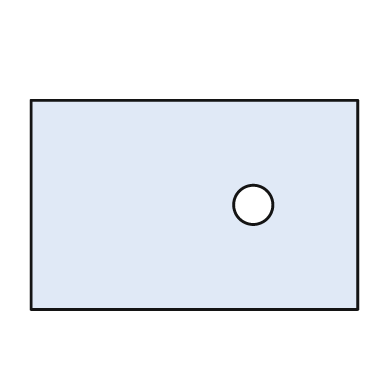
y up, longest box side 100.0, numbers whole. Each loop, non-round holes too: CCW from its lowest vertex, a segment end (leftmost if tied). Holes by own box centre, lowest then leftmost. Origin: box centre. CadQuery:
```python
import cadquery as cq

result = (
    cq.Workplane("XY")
    .moveTo(-50.0, -32.0)
    .lineTo(50.0, -32.0)
    .lineTo(50.0, 32.0)
    .lineTo(-50.0, 32.0)
    .close()
    .moveTo(18.0, 0.0)
    .circle(6.0)
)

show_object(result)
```